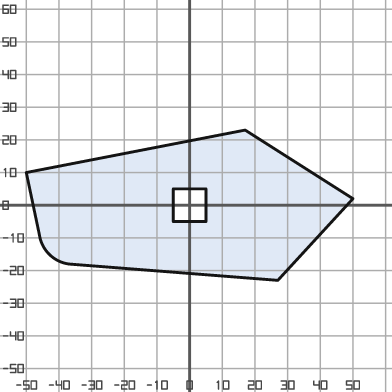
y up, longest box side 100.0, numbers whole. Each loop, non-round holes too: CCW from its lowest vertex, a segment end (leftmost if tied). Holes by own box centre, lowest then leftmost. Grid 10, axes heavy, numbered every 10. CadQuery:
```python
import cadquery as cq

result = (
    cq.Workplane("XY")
    .moveTo(27.0, -23.0)
    .lineTo(50.0, 2.0)
    .lineTo(17.0, 23.0)
    .lineTo(-50.0, 10.0)
    .lineTo(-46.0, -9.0)
    .threePointArc((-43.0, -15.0), (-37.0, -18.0))
    .close()
    .moveTo(-5.0, -5.0)
    .lineTo(5.0, -5.0)
    .lineTo(5.0, 5.0)
    .lineTo(-5.0, 5.0)
    .close()
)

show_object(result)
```